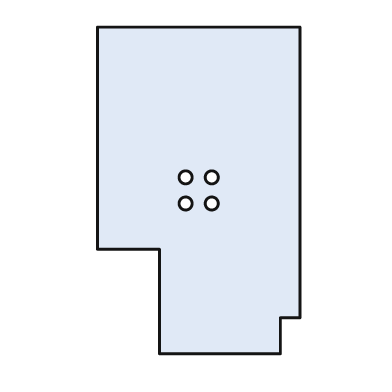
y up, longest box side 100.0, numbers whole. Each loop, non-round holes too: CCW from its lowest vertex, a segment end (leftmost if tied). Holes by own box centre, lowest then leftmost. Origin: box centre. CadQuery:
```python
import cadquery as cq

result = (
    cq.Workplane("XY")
    .moveTo(-12.0, -50.0)
    .lineTo(25.0, -50.0)
    .lineTo(25.0, -39.0)
    .lineTo(31.0, -39.0)
    .lineTo(31.0, 50.0)
    .lineTo(-31.0, 50.0)
    .lineTo(-31.0, -18.0)
    .lineTo(-12.0, -18.0)
    .close()
    .moveTo(-4.0, -4.0)
    .circle(2.0)
    .moveTo(4.0, -4.0)
    .circle(2.0)
    .moveTo(-4.0, 4.0)
    .circle(2.0)
    .moveTo(4.0, 4.0)
    .circle(2.0)
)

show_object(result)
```